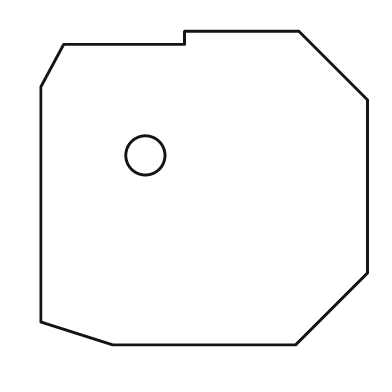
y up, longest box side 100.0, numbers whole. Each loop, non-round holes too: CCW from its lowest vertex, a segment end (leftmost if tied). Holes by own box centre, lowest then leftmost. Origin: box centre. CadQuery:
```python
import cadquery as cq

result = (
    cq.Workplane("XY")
    .moveTo(-28.0, -48.0)
    .lineTo(28.0, -48.0)
    .lineTo(50.0, -26.0)
    .lineTo(50.0, 27.0)
    .lineTo(29.0, 48.0)
    .lineTo(-6.0, 48.0)
    .lineTo(-6.0, 44.0)
    .lineTo(-43.0, 44.0)
    .lineTo(-50.0, 31.0)
    .lineTo(-50.0, -41.0)
    .close()
    .moveTo(-18.0, 10.0)
    .circle(6.0)
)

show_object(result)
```